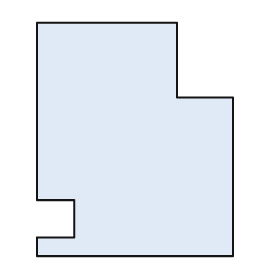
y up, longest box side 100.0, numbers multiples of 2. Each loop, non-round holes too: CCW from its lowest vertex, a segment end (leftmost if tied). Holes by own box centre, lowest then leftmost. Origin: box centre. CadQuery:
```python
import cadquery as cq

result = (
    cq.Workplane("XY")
    .moveTo(-42.0, -50.0)
    .lineTo(42.0, -50.0)
    .lineTo(42.0, 18.0)
    .lineTo(18.0, 18.0)
    .lineTo(18.0, 50.0)
    .lineTo(-42.0, 50.0)
    .lineTo(-42.0, -26.0)
    .lineTo(-26.0, -26.0)
    .lineTo(-26.0, -42.0)
    .lineTo(-42.0, -42.0)
    .close()
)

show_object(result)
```